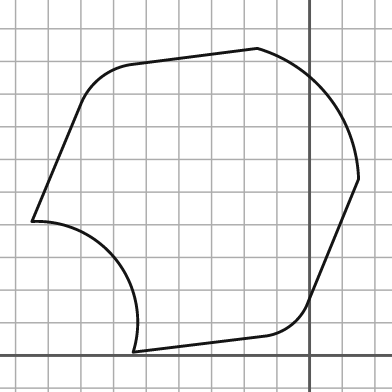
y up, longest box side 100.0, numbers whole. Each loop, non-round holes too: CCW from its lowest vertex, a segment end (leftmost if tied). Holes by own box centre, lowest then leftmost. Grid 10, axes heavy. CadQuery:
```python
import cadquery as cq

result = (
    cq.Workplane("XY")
    .moveTo(-54.0, 1.0)
    .lineTo(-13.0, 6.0)
    .threePointArc((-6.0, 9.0), (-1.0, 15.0))
    .lineTo(15.0, 54.0)
    .threePointArc((6.0, 79.0), (-16.0, 94.0))
    .lineTo(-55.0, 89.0)
    .threePointArc((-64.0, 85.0), (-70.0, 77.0))
    .lineTo(-85.0, 41.0)
    .threePointArc((-59.0, 29.0), (-54.0, 1.0))
    .close()
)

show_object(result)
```